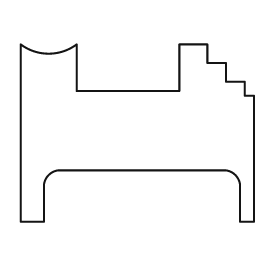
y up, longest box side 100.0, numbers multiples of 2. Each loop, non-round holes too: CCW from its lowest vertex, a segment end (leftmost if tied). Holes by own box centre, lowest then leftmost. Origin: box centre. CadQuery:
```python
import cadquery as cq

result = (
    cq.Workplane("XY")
    .moveTo(-50.0, -38.0)
    .lineTo(-40.0, -38.0)
    .lineTo(-40.0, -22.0)
    .threePointArc((-38.0, -18.0), (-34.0, -16.0))
    .lineTo(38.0, -16.0)
    .threePointArc((42.0, -18.0), (44.0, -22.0))
    .lineTo(44.0, -38.0)
    .lineTo(50.0, -38.0)
    .lineTo(50.0, 16.0)
    .lineTo(46.0, 16.0)
    .lineTo(46.0, 22.0)
    .lineTo(38.0, 22.0)
    .lineTo(38.0, 30.0)
    .lineTo(30.0, 30.0)
    .lineTo(30.0, 38.0)
    .lineTo(18.0, 38.0)
    .lineTo(18.0, 18.0)
    .lineTo(-26.0, 18.0)
    .lineTo(-26.0, 38.0)
    .threePointArc((-38.0, 34.0), (-50.0, 38.0))
    .close()
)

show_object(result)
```